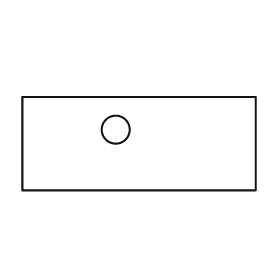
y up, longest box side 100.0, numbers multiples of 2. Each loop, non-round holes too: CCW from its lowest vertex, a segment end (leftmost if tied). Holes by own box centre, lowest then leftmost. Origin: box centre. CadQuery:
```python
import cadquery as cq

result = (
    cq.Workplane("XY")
    .moveTo(-50.0, -20.0)
    .lineTo(50.0, -20.0)
    .lineTo(50.0, 20.0)
    .lineTo(-50.0, 20.0)
    .close()
    .moveTo(-10.0, 6.0)
    .circle(6.0)
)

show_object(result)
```